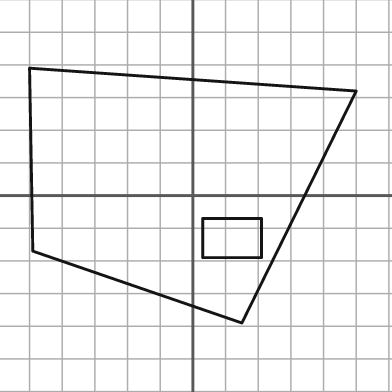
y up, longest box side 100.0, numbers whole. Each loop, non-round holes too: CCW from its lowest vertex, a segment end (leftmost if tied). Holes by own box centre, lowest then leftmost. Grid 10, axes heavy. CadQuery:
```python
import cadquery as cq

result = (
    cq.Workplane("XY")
    .moveTo(15.0, -39.0)
    .lineTo(50.0, 32.0)
    .lineTo(-50.0, 39.0)
    .lineTo(-49.0, -17.0)
    .close()
    .moveTo(3.0, -19.0)
    .lineTo(21.0, -19.0)
    .lineTo(21.0, -7.0)
    .lineTo(3.0, -7.0)
    .close()
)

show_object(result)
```